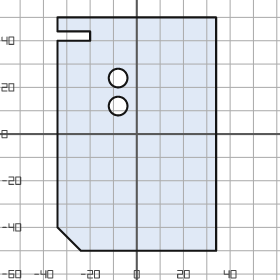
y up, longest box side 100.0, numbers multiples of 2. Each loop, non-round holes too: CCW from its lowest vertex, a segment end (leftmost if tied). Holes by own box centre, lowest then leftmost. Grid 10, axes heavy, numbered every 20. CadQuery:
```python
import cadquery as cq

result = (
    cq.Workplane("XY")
    .moveTo(-24.0, -50.0)
    .lineTo(34.0, -50.0)
    .lineTo(34.0, 50.0)
    .lineTo(-34.0, 50.0)
    .lineTo(-34.0, 44.0)
    .lineTo(-20.0, 44.0)
    .lineTo(-20.0, 40.0)
    .lineTo(-34.0, 40.0)
    .lineTo(-34.0, -40.0)
    .close()
    .moveTo(-8.0, 12.0)
    .circle(4.0)
    .moveTo(-8.0, 24.0)
    .circle(4.0)
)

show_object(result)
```